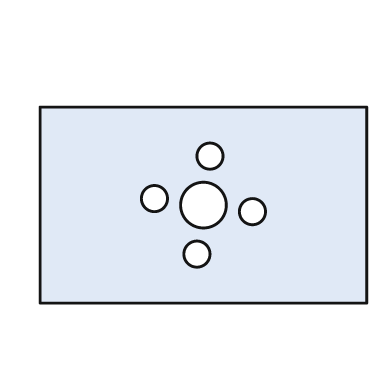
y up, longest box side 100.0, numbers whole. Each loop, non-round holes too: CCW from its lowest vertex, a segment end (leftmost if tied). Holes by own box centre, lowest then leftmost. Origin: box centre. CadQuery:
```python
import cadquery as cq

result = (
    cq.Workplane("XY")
    .moveTo(-50.0, -30.0)
    .lineTo(50.0, -30.0)
    .lineTo(50.0, 30.0)
    .lineTo(-50.0, 30.0)
    .close()
    .moveTo(-2.0, -15.0)
    .circle(4.0)
    .moveTo(15.0, -2.0)
    .circle(4.0)
    .moveTo(0.0, 0.0)
    .circle(7.0)
    .moveTo(-15.0, 2.0)
    .circle(4.0)
    .moveTo(2.0, 15.0)
    .circle(4.0)
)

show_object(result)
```